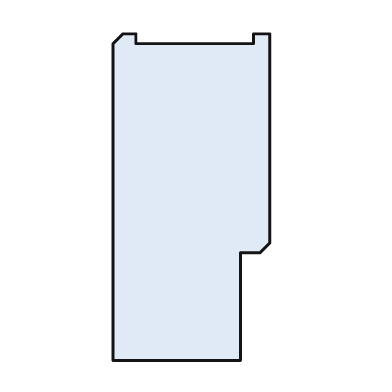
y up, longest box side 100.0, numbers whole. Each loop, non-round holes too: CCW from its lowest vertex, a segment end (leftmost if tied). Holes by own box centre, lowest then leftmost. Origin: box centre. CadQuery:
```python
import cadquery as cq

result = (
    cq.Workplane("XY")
    .moveTo(-24.0, -50.0)
    .lineTo(15.0, -50.0)
    .lineTo(15.0, -17.0)
    .lineTo(21.0, -17.0)
    .lineTo(24.0, -14.0)
    .lineTo(24.0, 50.0)
    .lineTo(19.0, 50.0)
    .lineTo(19.0, 47.0)
    .lineTo(-17.0, 47.0)
    .lineTo(-17.0, 50.0)
    .lineTo(-21.0, 50.0)
    .lineTo(-24.0, 47.0)
    .close()
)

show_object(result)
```